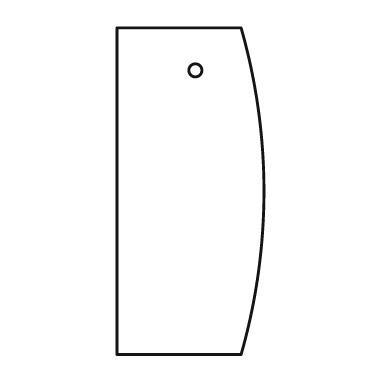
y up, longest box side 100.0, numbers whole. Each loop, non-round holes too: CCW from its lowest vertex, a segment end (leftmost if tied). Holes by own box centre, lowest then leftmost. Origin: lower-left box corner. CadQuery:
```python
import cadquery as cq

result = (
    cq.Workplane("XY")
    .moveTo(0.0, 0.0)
    .lineTo(38.0, 0.0)
    .threePointArc((45.0, 50.0), (38.0, 100.0))
    .lineTo(0.0, 100.0)
    .close()
    .moveTo(24.0, 87.0)
    .circle(2.0)
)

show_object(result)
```